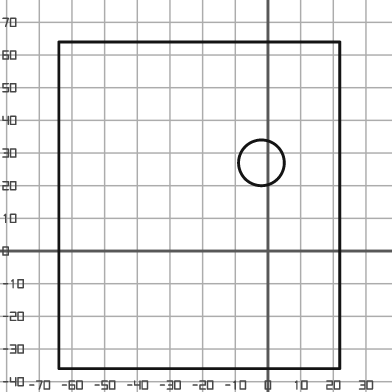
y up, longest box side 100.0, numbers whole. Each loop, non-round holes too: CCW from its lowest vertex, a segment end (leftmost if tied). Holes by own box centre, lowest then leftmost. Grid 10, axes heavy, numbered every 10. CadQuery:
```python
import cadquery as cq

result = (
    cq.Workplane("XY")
    .moveTo(-64.0, -36.0)
    .lineTo(22.0, -36.0)
    .lineTo(22.0, 64.0)
    .lineTo(-64.0, 64.0)
    .close()
    .moveTo(-2.0, 27.0)
    .circle(7.0)
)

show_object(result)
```